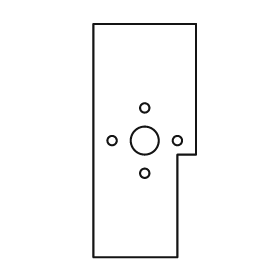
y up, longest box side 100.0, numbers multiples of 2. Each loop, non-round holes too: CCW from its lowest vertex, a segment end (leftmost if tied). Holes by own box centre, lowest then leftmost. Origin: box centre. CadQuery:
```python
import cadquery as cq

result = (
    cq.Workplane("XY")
    .moveTo(-22.0, -50.0)
    .lineTo(14.0, -50.0)
    .lineTo(14.0, -6.0)
    .lineTo(22.0, -6.0)
    .lineTo(22.0, 50.0)
    .lineTo(-22.0, 50.0)
    .close()
    .moveTo(0.0, -14.0)
    .circle(2.0)
    .moveTo(-14.0, 0.0)
    .circle(2.0)
    .moveTo(0.0, 0.0)
    .circle(6.0)
    .moveTo(14.0, 0.0)
    .circle(2.0)
    .moveTo(0.0, 14.0)
    .circle(2.0)
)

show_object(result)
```